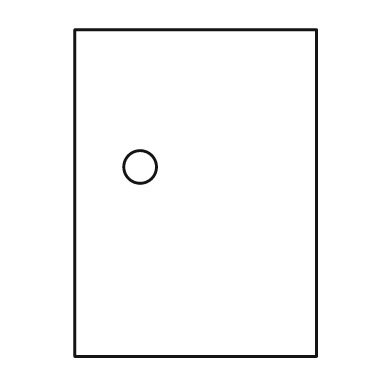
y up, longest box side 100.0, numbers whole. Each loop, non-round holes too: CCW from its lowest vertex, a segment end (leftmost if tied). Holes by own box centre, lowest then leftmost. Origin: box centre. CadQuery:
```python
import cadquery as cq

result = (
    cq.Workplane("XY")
    .moveTo(-37.0, -50.0)
    .lineTo(37.0, -50.0)
    .lineTo(37.0, 50.0)
    .lineTo(-37.0, 50.0)
    .close()
    .moveTo(-17.0, 8.0)
    .circle(5.0)
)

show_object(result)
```